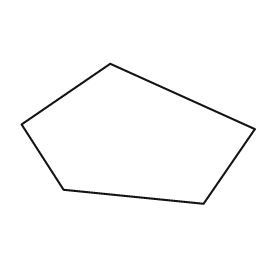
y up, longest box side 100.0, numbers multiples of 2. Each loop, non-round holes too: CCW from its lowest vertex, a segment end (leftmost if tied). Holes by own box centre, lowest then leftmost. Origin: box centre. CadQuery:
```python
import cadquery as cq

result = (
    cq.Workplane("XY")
    .moveTo(28.0, -30.0)
    .lineTo(50.0, 2.0)
    .lineTo(-12.0, 30.0)
    .lineTo(-50.0, 4.0)
    .lineTo(-32.0, -24.0)
    .close()
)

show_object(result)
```